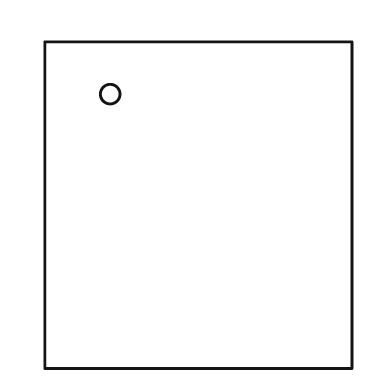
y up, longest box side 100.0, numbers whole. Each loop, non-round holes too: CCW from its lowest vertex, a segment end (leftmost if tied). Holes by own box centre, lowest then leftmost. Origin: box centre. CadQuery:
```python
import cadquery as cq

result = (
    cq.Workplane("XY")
    .moveTo(-47.0, -50.0)
    .lineTo(47.0, -50.0)
    .lineTo(47.0, 50.0)
    .lineTo(-47.0, 50.0)
    .close()
    .moveTo(-27.0, 34.0)
    .circle(3.0)
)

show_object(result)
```